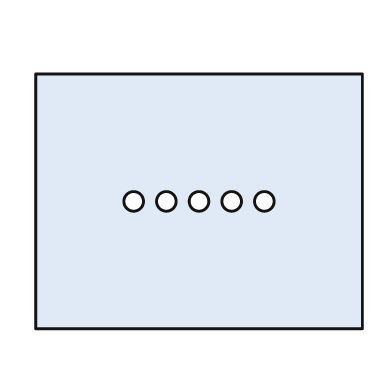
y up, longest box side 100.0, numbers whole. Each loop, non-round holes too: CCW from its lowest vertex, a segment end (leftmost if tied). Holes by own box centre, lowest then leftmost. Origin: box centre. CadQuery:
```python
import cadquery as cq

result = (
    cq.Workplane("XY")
    .moveTo(-50.0, -39.0)
    .lineTo(50.0, -39.0)
    .lineTo(50.0, 39.0)
    .lineTo(-50.0, 39.0)
    .close()
    .moveTo(-20.0, 0.0)
    .circle(3.0)
    .moveTo(-10.0, 0.0)
    .circle(3.0)
    .moveTo(0.0, 0.0)
    .circle(3.0)
    .moveTo(10.0, 0.0)
    .circle(3.0)
    .moveTo(20.0, 0.0)
    .circle(3.0)
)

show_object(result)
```